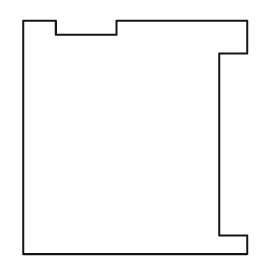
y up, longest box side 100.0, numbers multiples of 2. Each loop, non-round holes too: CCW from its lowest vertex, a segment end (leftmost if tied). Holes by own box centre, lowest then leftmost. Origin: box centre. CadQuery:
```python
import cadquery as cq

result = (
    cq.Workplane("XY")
    .moveTo(-48.0, -50.0)
    .lineTo(48.0, -50.0)
    .lineTo(48.0, -42.0)
    .lineTo(36.0, -42.0)
    .lineTo(36.0, 36.0)
    .lineTo(48.0, 36.0)
    .lineTo(48.0, 50.0)
    .lineTo(-8.0, 50.0)
    .lineTo(-8.0, 44.0)
    .lineTo(-34.0, 44.0)
    .lineTo(-34.0, 50.0)
    .lineTo(-48.0, 50.0)
    .close()
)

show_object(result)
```